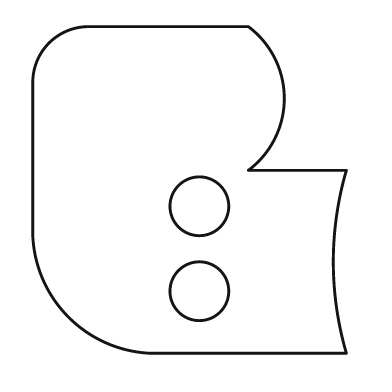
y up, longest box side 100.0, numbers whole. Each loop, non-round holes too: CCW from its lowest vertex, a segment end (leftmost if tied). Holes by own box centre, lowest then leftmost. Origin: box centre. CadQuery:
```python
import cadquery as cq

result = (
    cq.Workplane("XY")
    .moveTo(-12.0, -50.0)
    .lineTo(48.0, -50.0)
    .threePointArc((44.0, -22.0), (48.0, 6.0))
    .lineTo(18.0, 6.0)
    .threePointArc((29.0, 28.0), (18.0, 50.0))
    .lineTo(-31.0, 50.0)
    .threePointArc((-43.0, 45.0), (-48.0, 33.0))
    .lineTo(-48.0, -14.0)
    .threePointArc((-37.0, -39.0), (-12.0, -50.0))
    .close()
    .moveTo(3.0, -31.0)
    .circle(9.0)
    .moveTo(3.0, -5.0)
    .circle(9.0)
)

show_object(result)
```